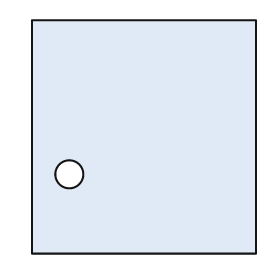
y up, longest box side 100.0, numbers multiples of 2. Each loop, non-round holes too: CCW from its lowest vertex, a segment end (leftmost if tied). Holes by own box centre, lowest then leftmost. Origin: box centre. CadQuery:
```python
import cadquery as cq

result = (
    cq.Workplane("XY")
    .moveTo(-48.0, -50.0)
    .lineTo(48.0, -50.0)
    .lineTo(48.0, 50.0)
    .lineTo(-48.0, 50.0)
    .close()
    .moveTo(-32.0, -16.0)
    .circle(6.0)
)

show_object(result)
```